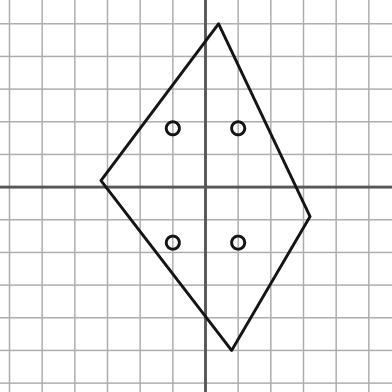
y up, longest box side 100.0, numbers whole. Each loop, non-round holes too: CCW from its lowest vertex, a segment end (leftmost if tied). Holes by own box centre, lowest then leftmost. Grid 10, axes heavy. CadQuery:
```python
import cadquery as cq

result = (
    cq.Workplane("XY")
    .moveTo(8.0, -50.0)
    .lineTo(32.0, -9.0)
    .lineTo(4.0, 50.0)
    .lineTo(-32.0, 2.0)
    .close()
    .moveTo(-10.0, -17.0)
    .circle(2.0)
    .moveTo(10.0, -17.0)
    .circle(2.0)
    .moveTo(-10.0, 18.0)
    .circle(2.0)
    .moveTo(10.0, 18.0)
    .circle(2.0)
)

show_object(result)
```